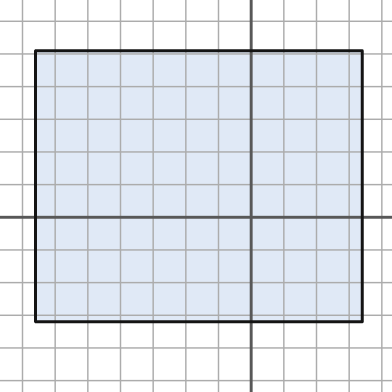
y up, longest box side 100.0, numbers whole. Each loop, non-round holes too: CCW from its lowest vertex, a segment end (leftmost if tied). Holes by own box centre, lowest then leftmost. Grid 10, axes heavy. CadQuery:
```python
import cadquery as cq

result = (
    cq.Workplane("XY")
    .moveTo(-66.0, -32.0)
    .lineTo(34.0, -32.0)
    .lineTo(34.0, 51.0)
    .lineTo(-66.0, 51.0)
    .close()
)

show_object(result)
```